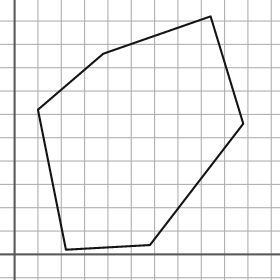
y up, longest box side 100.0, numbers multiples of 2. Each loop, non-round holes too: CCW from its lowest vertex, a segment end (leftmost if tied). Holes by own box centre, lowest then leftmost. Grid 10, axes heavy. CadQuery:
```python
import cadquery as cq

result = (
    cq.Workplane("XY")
    .moveTo(22.0, 2.0)
    .lineTo(58.0, 4.0)
    .lineTo(98.0, 56.0)
    .lineTo(84.0, 102.0)
    .lineTo(38.0, 86.0)
    .lineTo(10.0, 62.0)
    .close()
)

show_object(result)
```